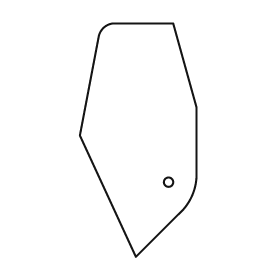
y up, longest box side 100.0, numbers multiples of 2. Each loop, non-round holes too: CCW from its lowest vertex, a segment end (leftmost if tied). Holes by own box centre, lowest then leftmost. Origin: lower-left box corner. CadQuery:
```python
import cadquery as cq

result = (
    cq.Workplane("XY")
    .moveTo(24.0, 0.0)
    .lineTo(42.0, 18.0)
    .threePointArc((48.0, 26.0), (50.0, 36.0))
    .lineTo(50.0, 64.0)
    .lineTo(40.0, 100.0)
    .lineTo(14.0, 100.0)
    .threePointArc((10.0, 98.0), (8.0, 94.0))
    .lineTo(0.0, 52.0)
    .close()
    .moveTo(38.0, 32.0)
    .circle(2.0)
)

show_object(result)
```